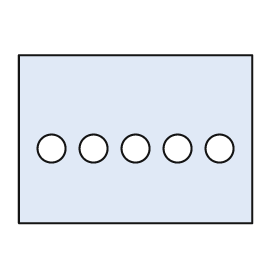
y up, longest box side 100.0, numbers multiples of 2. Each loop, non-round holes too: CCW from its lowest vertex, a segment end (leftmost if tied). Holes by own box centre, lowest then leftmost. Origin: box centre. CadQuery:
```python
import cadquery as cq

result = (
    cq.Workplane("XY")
    .moveTo(-50.0, -36.0)
    .lineTo(50.0, -36.0)
    .lineTo(50.0, 36.0)
    .lineTo(-50.0, 36.0)
    .close()
    .moveTo(-36.0, -4.0)
    .circle(6.0)
    .moveTo(-18.0, -4.0)
    .circle(6.0)
    .moveTo(0.0, -4.0)
    .circle(6.0)
    .moveTo(18.0, -4.0)
    .circle(6.0)
    .moveTo(36.0, -4.0)
    .circle(6.0)
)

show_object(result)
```